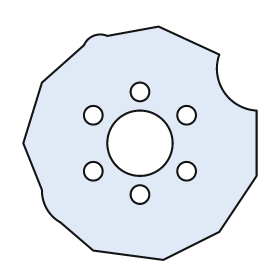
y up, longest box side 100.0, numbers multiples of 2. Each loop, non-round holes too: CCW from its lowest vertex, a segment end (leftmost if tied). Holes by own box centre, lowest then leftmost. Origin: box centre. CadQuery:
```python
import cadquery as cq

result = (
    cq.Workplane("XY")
    .moveTo(10.0, -50.0)
    .lineTo(34.0, -38.0)
    .lineTo(50.0, -14.0)
    .lineTo(50.0, 14.0)
    .threePointArc((36.0, 22.0), (34.0, 38.0))
    .lineTo(8.0, 50.0)
    .lineTo(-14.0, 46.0)
    .threePointArc((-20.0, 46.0), (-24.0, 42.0))
    .lineTo(-42.0, 26.0)
    .lineTo(-50.0, 0.0)
    .lineTo(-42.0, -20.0)
    .threePointArc((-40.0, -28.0), (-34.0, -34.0))
    .lineTo(-20.0, -46.0)
    .close()
    .moveTo(0.0, -22.0)
    .circle(4.0)
    .moveTo(-20.0, -12.0)
    .circle(4.0)
    .moveTo(20.0, -12.0)
    .circle(4.0)
    .moveTo(0.0, 0.0)
    .circle(14.0)
    .moveTo(-20.0, 12.0)
    .circle(4.0)
    .moveTo(20.0, 12.0)
    .circle(4.0)
    .moveTo(0.0, 22.0)
    .circle(4.0)
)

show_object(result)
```